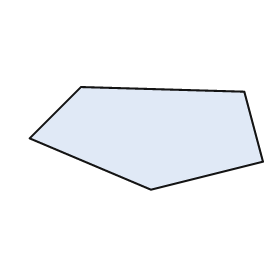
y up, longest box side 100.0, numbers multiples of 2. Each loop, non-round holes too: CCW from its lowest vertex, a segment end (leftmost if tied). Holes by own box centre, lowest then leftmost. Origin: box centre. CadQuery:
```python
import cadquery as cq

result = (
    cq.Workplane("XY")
    .moveTo(2.0, -22.0)
    .lineTo(50.0, -10.0)
    .lineTo(42.0, 20.0)
    .lineTo(-28.0, 22.0)
    .lineTo(-50.0, 0.0)
    .close()
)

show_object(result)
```